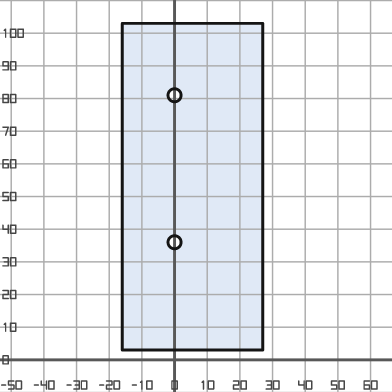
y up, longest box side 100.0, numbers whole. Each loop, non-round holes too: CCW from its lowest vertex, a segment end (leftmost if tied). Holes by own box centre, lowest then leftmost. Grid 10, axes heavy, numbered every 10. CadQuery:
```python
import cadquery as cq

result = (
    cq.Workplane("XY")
    .moveTo(-16.0, 3.0)
    .lineTo(27.0, 3.0)
    .lineTo(27.0, 103.0)
    .lineTo(-16.0, 103.0)
    .close()
    .moveTo(0.0, 36.0)
    .circle(2.0)
    .moveTo(0.0, 81.0)
    .circle(2.0)
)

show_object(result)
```